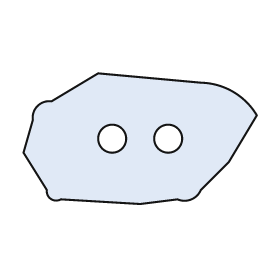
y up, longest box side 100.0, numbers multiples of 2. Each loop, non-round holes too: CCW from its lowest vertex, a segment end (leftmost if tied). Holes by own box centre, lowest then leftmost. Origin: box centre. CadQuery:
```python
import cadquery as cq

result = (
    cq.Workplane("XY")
    .moveTo(0.0, -28.0)
    .lineTo(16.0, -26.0)
    .threePointArc((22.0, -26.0), (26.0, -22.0))
    .lineTo(38.0, -10.0)
    .lineTo(50.0, 10.0)
    .threePointArc((40.0, 20.0), (26.0, 24.0))
    .lineTo(-18.0, 28.0)
    .lineTo(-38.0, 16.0)
    .threePointArc((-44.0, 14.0), (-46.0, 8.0))
    .lineTo(-50.0, -6.0)
    .lineTo(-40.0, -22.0)
    .threePointArc((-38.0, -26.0), (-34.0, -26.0))
    .close()
    .moveTo(-12.0, 0.0)
    .circle(6.0)
    .moveTo(12.0, 0.0)
    .circle(6.0)
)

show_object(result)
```